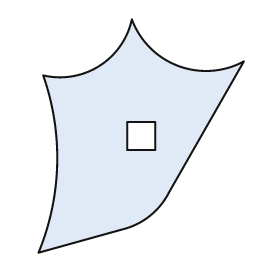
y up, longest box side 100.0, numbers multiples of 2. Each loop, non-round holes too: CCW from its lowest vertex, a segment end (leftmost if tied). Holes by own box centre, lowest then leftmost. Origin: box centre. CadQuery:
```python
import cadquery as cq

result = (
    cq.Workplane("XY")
    .moveTo(-44.0, -50.0)
    .lineTo(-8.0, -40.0)
    .threePointArc((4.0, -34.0), (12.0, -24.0))
    .lineTo(44.0, 32.0)
    .threePointArc((16.0, 30.0), (-4.0, 50.0))
    .threePointArc((-18.0, 30.0), (-42.0, 26.0))
    .threePointArc((-36.0, -12.0), (-44.0, -50.0))
    .close()
    .moveTo(-6.0, -6.0)
    .lineTo(6.0, -6.0)
    .lineTo(6.0, 6.0)
    .lineTo(-6.0, 6.0)
    .close()
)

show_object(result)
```